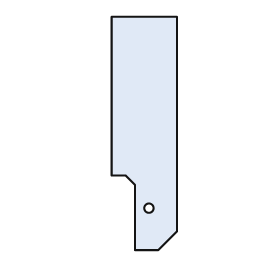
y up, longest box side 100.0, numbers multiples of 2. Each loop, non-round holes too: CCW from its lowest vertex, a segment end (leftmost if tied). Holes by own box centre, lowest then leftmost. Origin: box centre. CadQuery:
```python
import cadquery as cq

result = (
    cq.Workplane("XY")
    .moveTo(-4.0, -50.0)
    .lineTo(6.0, -50.0)
    .lineTo(14.0, -42.0)
    .lineTo(14.0, 50.0)
    .lineTo(-14.0, 50.0)
    .lineTo(-14.0, -18.0)
    .lineTo(-8.0, -18.0)
    .lineTo(-4.0, -22.0)
    .close()
    .moveTo(2.0, -32.0)
    .circle(2.0)
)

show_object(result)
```